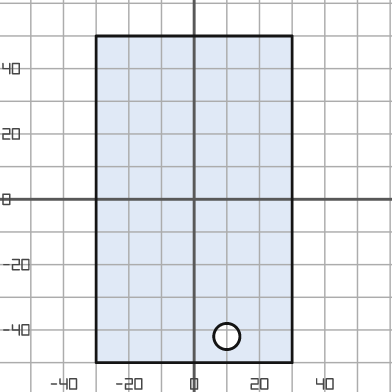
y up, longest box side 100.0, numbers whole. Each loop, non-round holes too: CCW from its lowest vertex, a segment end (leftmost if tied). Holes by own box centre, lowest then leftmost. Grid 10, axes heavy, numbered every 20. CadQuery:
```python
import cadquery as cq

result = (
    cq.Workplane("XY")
    .moveTo(-30.0, -50.0)
    .lineTo(30.0, -50.0)
    .lineTo(30.0, 50.0)
    .lineTo(-30.0, 50.0)
    .close()
    .moveTo(10.0, -42.0)
    .circle(4.0)
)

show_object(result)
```